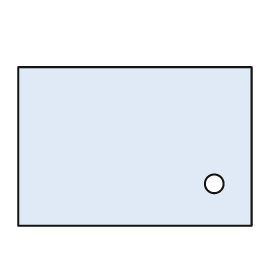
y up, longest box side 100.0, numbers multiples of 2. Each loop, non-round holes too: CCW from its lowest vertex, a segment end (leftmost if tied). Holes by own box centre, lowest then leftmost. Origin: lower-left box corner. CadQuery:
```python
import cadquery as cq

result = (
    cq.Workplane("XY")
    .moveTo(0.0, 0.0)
    .lineTo(100.0, 0.0)
    .lineTo(100.0, 68.0)
    .lineTo(0.0, 68.0)
    .close()
    .moveTo(84.0, 18.0)
    .circle(4.0)
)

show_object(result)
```